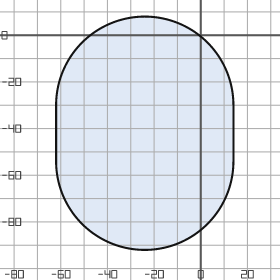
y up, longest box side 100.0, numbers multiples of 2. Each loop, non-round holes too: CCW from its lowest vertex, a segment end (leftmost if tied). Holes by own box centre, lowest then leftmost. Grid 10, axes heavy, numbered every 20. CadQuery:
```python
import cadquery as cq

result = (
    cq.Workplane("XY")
    .moveTo(-62.0, -54.0)
    .threePointArc((-24.0, -92.0), (14.0, -54.0))
    .lineTo(14.0, -30.0)
    .threePointArc((-24.0, 8.0), (-62.0, -30.0))
    .close()
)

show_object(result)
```